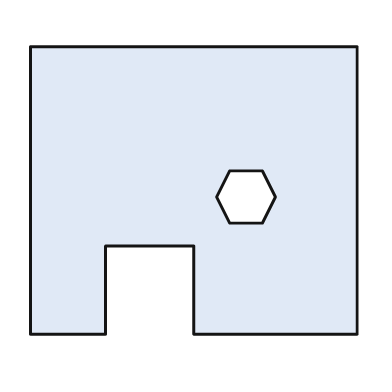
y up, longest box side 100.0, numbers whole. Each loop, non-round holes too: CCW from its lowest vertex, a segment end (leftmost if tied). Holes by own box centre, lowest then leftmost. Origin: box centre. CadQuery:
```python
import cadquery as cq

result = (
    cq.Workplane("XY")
    .moveTo(-50.0, -44.0)
    .lineTo(-27.0, -44.0)
    .lineTo(-27.0, -17.0)
    .lineTo(0.0, -17.0)
    .lineTo(0.0, -44.0)
    .lineTo(50.0, -44.0)
    .lineTo(50.0, 44.0)
    .lineTo(-50.0, 44.0)
    .close()
    .moveTo(11.0, -10.0)
    .lineTo(21.0, -10.0)
    .lineTo(25.0, -2.0)
    .lineTo(21.0, 6.0)
    .lineTo(11.0, 6.0)
    .lineTo(7.0, -2.0)
    .close()
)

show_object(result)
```